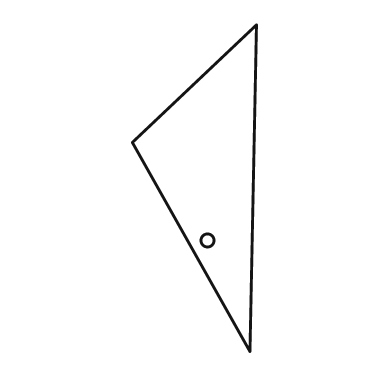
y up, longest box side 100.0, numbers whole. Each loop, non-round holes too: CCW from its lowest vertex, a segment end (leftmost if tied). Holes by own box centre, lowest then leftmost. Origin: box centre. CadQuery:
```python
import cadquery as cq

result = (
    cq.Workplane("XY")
    .moveTo(17.0, -50.0)
    .lineTo(19.0, 50.0)
    .lineTo(-19.0, 14.0)
    .close()
    .moveTo(4.0, -16.0)
    .circle(2.0)
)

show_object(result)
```